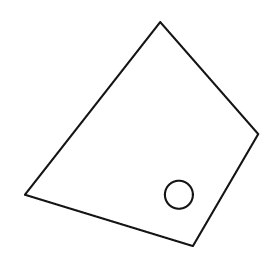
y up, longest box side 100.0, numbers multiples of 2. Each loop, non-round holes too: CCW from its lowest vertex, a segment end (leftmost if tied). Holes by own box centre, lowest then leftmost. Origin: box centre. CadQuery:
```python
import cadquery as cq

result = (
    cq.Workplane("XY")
    .moveTo(22.0, -48.0)
    .lineTo(50.0, 0.0)
    .lineTo(8.0, 48.0)
    .lineTo(-50.0, -26.0)
    .close()
    .moveTo(16.0, -26.0)
    .circle(6.0)
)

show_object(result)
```